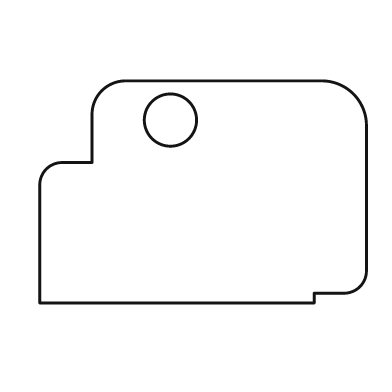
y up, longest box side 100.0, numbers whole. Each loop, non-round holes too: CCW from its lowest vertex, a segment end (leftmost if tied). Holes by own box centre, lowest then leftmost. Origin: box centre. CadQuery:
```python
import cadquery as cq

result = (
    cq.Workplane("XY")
    .moveTo(-50.0, -34.0)
    .lineTo(34.0, -34.0)
    .lineTo(34.0, -31.0)
    .lineTo(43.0, -31.0)
    .threePointArc((48.0, -29.0), (50.0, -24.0))
    .lineTo(50.0, 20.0)
    .threePointArc((46.0, 30.0), (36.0, 34.0))
    .lineTo(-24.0, 34.0)
    .threePointArc((-31.0, 31.0), (-34.0, 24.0))
    .lineTo(-34.0, 9.0)
    .lineTo(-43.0, 9.0)
    .threePointArc((-48.0, 7.0), (-50.0, 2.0))
    .close()
    .moveTo(-10.0, 22.0)
    .circle(8.0)
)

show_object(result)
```